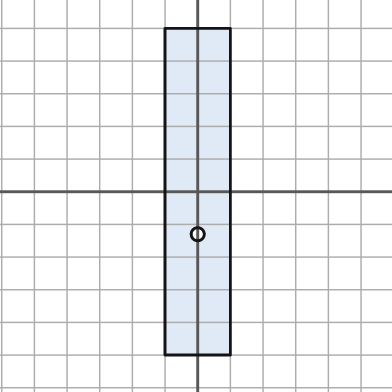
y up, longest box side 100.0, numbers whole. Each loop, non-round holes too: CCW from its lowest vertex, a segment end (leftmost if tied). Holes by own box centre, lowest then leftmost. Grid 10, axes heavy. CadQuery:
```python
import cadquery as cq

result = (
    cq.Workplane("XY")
    .moveTo(-10.0, -50.0)
    .lineTo(10.0, -50.0)
    .lineTo(10.0, 50.0)
    .lineTo(-10.0, 50.0)
    .close()
    .moveTo(0.0, -13.0)
    .circle(2.0)
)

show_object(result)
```